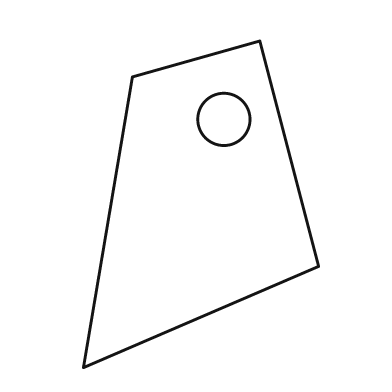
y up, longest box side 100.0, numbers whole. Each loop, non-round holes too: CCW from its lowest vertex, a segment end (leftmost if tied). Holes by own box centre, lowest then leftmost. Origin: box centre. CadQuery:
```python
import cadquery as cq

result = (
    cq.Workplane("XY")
    .moveTo(-36.0, -50.0)
    .lineTo(36.0, -19.0)
    .lineTo(18.0, 50.0)
    .lineTo(-21.0, 39.0)
    .close()
    .moveTo(7.0, 26.0)
    .circle(8.0)
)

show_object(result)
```